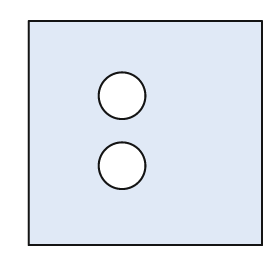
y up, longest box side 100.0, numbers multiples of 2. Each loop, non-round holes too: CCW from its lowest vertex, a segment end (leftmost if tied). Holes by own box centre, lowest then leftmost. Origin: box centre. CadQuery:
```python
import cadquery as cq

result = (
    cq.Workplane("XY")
    .moveTo(-50.0, -48.0)
    .lineTo(50.0, -48.0)
    .lineTo(50.0, 48.0)
    .lineTo(-50.0, 48.0)
    .close()
    .moveTo(-10.0, -14.0)
    .circle(10.0)
    .moveTo(-10.0, 16.0)
    .circle(10.0)
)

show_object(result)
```